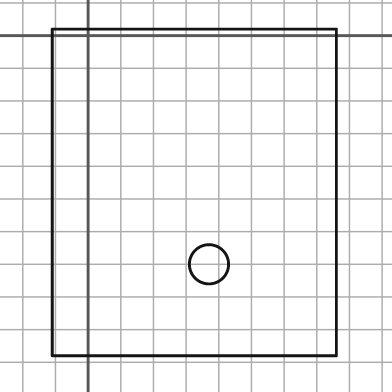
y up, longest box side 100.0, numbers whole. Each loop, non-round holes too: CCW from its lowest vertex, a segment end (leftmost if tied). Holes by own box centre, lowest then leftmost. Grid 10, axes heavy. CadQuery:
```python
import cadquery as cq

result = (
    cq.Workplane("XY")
    .moveTo(-11.0, -98.0)
    .lineTo(76.0, -98.0)
    .lineTo(76.0, 2.0)
    .lineTo(-11.0, 2.0)
    .close()
    .moveTo(37.0, -70.0)
    .circle(6.0)
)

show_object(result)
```